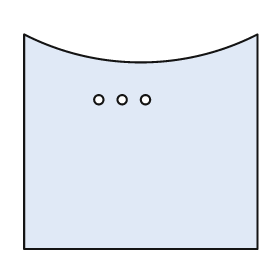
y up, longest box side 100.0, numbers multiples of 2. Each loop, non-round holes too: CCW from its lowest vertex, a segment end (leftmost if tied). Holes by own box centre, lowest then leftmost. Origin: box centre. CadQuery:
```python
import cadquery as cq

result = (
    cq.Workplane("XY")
    .moveTo(-50.0, -46.0)
    .lineTo(50.0, -46.0)
    .lineTo(50.0, 46.0)
    .threePointArc((0.0, 34.0), (-50.0, 46.0))
    .close()
    .moveTo(-18.0, 18.0)
    .circle(2.0)
    .moveTo(-8.0, 18.0)
    .circle(2.0)
    .moveTo(2.0, 18.0)
    .circle(2.0)
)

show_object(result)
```